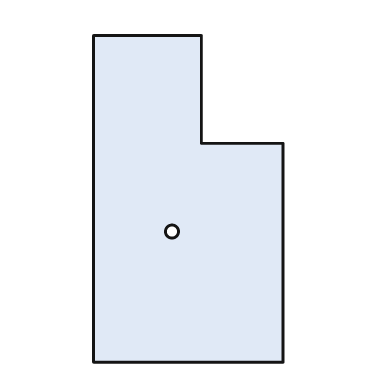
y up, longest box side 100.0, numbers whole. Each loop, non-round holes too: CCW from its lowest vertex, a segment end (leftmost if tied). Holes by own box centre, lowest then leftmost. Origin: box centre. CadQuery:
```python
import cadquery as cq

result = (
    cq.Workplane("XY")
    .moveTo(-29.0, -50.0)
    .lineTo(29.0, -50.0)
    .lineTo(29.0, 17.0)
    .lineTo(4.0, 17.0)
    .lineTo(4.0, 50.0)
    .lineTo(-29.0, 50.0)
    .close()
    .moveTo(-5.0, -10.0)
    .circle(2.0)
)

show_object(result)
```